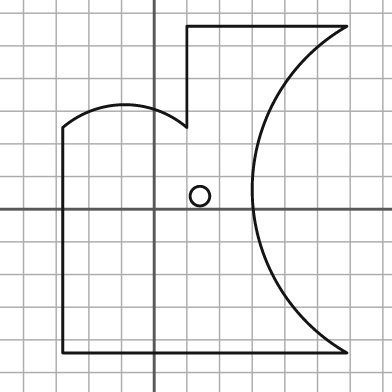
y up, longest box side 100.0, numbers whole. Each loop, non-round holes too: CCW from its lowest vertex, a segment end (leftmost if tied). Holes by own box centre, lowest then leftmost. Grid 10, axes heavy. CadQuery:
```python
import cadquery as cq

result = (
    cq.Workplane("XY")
    .moveTo(-28.0, -44.0)
    .lineTo(59.0, -44.0)
    .threePointArc((30.0, 6.0), (59.0, 56.0))
    .lineTo(10.0, 56.0)
    .lineTo(10.0, 25.0)
    .threePointArc((-9.0, 32.0), (-28.0, 25.0))
    .close()
    .moveTo(14.0, 4.0)
    .circle(3.0)
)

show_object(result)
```